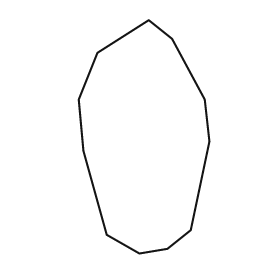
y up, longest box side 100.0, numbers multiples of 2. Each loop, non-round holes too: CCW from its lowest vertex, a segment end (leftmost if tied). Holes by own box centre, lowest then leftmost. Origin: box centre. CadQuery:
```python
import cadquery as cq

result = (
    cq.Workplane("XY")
    .moveTo(-2.0, -50.0)
    .lineTo(10.0, -48.0)
    .lineTo(20.0, -40.0)
    .lineTo(28.0, -2.0)
    .lineTo(26.0, 16.0)
    .lineTo(12.0, 42.0)
    .lineTo(2.0, 50.0)
    .lineTo(-20.0, 36.0)
    .lineTo(-28.0, 16.0)
    .lineTo(-26.0, -6.0)
    .lineTo(-16.0, -42.0)
    .close()
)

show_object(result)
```